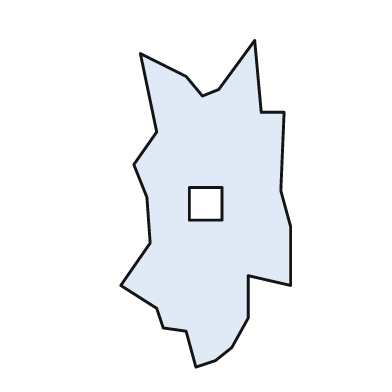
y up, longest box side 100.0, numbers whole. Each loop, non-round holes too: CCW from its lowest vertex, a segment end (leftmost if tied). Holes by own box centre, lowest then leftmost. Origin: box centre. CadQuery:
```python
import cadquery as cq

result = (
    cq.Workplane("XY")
    .moveTo(-3.0, -50.0)
    .lineTo(3.0, -48.0)
    .lineTo(8.0, -44.0)
    .lineTo(13.0, -35.0)
    .lineTo(13.0, -22.0)
    .lineTo(26.0, -25.0)
    .lineTo(26.0, -7.0)
    .lineTo(23.0, 4.0)
    .lineTo(24.0, 28.0)
    .lineTo(17.0, 28.0)
    .lineTo(15.0, 50.0)
    .lineTo(4.0, 35.0)
    .lineTo(-1.0, 33.0)
    .lineTo(-6.0, 39.0)
    .lineTo(-20.0, 46.0)
    .lineTo(-15.0, 22.0)
    .lineTo(-22.0, 12.0)
    .lineTo(-18.0, 2.0)
    .lineTo(-17.0, -12.0)
    .lineTo(-26.0, -25.0)
    .lineTo(-15.0, -32.0)
    .lineTo(-13.0, -38.0)
    .lineTo(-6.0, -39.0)
    .close()
    .moveTo(-5.0, -5.0)
    .lineTo(5.0, -5.0)
    .lineTo(5.0, 5.0)
    .lineTo(-5.0, 5.0)
    .close()
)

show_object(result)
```